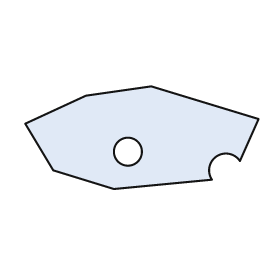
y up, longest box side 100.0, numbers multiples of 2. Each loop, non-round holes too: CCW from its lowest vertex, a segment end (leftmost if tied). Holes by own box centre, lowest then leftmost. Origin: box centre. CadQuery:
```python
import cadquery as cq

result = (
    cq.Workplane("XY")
    .moveTo(-12.0, -22.0)
    .lineTo(30.0, -18.0)
    .threePointArc((32.0, -8.0), (42.0, -10.0))
    .lineTo(50.0, 8.0)
    .lineTo(4.0, 22.0)
    .lineTo(-24.0, 18.0)
    .lineTo(-50.0, 6.0)
    .lineTo(-38.0, -14.0)
    .close()
    .moveTo(-6.0, -6.0)
    .circle(6.0)
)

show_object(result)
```